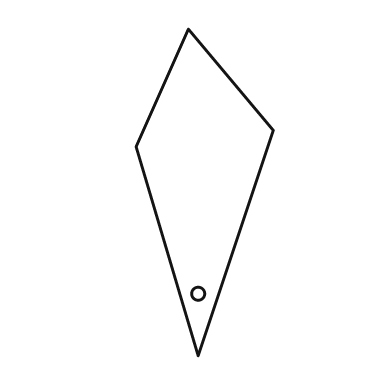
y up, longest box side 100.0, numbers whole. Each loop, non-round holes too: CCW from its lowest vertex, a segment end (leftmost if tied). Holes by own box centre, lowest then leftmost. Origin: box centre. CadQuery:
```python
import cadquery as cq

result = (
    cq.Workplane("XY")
    .moveTo(-2.0, -50.0)
    .lineTo(21.0, 19.0)
    .lineTo(-5.0, 50.0)
    .lineTo(-21.0, 14.0)
    .close()
    .moveTo(-2.0, -31.0)
    .circle(2.0)
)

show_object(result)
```